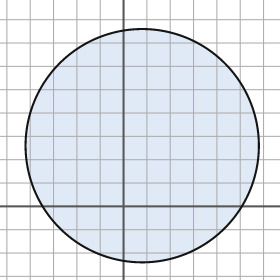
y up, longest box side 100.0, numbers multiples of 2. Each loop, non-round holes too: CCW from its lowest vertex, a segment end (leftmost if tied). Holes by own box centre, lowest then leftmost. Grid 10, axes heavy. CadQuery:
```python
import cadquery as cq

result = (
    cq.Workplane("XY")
    .moveTo(8.0, 26.0)
    .circle(50.0)
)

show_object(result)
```